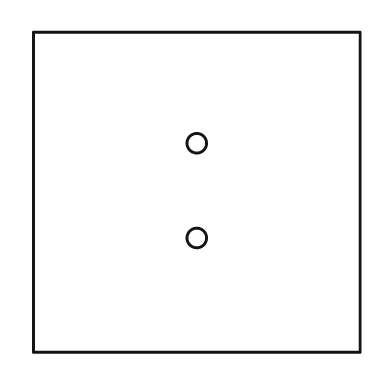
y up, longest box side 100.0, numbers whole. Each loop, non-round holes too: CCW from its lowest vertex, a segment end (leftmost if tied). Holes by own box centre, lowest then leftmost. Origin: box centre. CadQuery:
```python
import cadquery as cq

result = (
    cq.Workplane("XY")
    .moveTo(-50.0, -49.0)
    .lineTo(50.0, -49.0)
    .lineTo(50.0, 49.0)
    .lineTo(-50.0, 49.0)
    .close()
    .moveTo(0.0, -14.0)
    .circle(3.0)
    .moveTo(0.0, 15.0)
    .circle(3.0)
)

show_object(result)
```